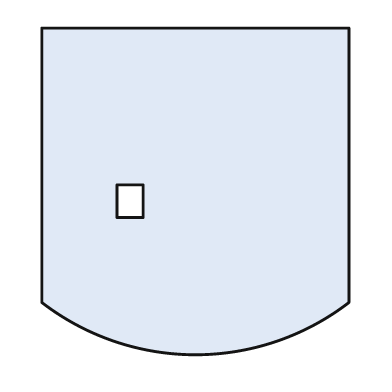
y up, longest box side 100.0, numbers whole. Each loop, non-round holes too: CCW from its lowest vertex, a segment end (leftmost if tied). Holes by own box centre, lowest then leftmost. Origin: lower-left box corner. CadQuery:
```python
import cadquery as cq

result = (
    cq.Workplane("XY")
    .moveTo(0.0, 16.0)
    .threePointArc((47.0, 0.0), (94.0, 16.0))
    .lineTo(94.0, 100.0)
    .lineTo(0.0, 100.0)
    .close()
    .moveTo(23.0, 42.0)
    .lineTo(31.0, 42.0)
    .lineTo(31.0, 52.0)
    .lineTo(23.0, 52.0)
    .close()
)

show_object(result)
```